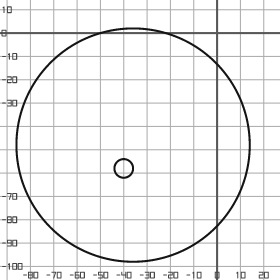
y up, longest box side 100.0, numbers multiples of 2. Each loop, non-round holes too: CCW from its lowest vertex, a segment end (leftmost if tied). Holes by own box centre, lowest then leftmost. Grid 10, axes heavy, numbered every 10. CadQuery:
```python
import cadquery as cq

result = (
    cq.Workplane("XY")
    .moveTo(-36.0, -48.0)
    .circle(50.0)
    .moveTo(-40.0, -58.0)
    .circle(4.0)
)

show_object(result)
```